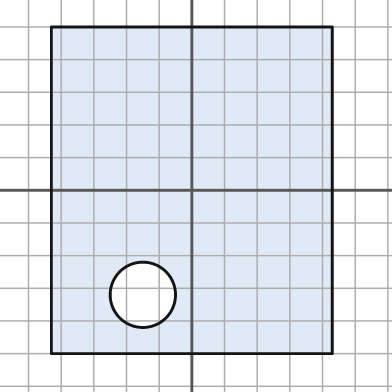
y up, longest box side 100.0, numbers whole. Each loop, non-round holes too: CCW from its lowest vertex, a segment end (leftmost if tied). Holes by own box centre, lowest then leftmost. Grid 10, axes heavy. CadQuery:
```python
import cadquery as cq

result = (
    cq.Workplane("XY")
    .moveTo(-43.0, -50.0)
    .lineTo(43.0, -50.0)
    .lineTo(43.0, 50.0)
    .lineTo(-43.0, 50.0)
    .close()
    .moveTo(-15.0, -32.0)
    .circle(10.0)
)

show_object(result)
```